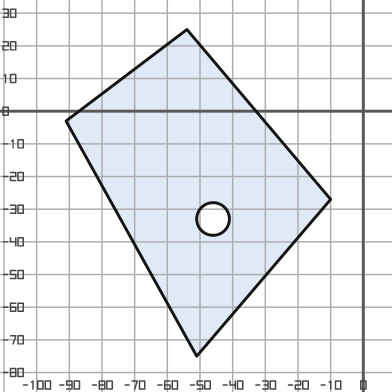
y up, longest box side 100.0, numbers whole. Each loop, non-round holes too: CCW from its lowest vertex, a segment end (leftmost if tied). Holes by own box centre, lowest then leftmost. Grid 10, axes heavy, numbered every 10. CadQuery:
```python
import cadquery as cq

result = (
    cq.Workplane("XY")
    .moveTo(-51.0, -75.0)
    .lineTo(-10.0, -27.0)
    .lineTo(-54.0, 25.0)
    .lineTo(-91.0, -3.0)
    .close()
    .moveTo(-46.0, -33.0)
    .circle(5.0)
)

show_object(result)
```